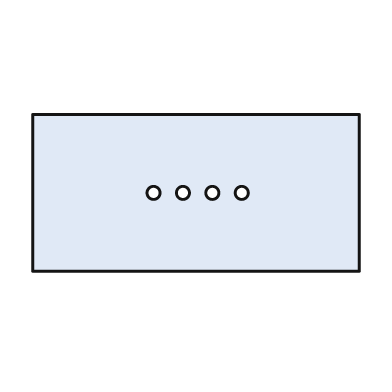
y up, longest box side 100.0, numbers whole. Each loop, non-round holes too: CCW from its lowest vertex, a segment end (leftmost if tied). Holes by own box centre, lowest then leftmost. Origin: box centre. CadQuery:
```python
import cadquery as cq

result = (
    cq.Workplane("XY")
    .moveTo(-50.0, -24.0)
    .lineTo(50.0, -24.0)
    .lineTo(50.0, 24.0)
    .lineTo(-50.0, 24.0)
    .close()
    .moveTo(-13.0, 0.0)
    .circle(2.0)
    .moveTo(-4.0, 0.0)
    .circle(2.0)
    .moveTo(5.0, 0.0)
    .circle(2.0)
    .moveTo(14.0, 0.0)
    .circle(2.0)
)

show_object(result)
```